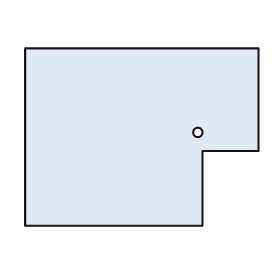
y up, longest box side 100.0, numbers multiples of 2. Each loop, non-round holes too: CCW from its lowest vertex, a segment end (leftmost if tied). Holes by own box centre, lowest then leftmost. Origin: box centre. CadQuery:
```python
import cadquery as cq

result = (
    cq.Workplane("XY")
    .moveTo(-50.0, -38.0)
    .lineTo(26.0, -38.0)
    .lineTo(26.0, -6.0)
    .lineTo(50.0, -6.0)
    .lineTo(50.0, 38.0)
    .lineTo(-50.0, 38.0)
    .close()
    .moveTo(24.0, 2.0)
    .circle(2.0)
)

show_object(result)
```